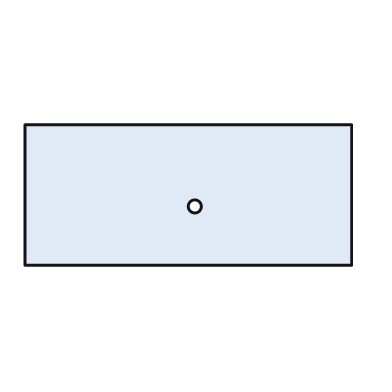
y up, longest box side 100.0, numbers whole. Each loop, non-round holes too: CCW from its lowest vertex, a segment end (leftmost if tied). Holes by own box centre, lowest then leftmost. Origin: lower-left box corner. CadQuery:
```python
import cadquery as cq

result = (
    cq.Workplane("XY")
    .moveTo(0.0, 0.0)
    .lineTo(100.0, 0.0)
    .lineTo(100.0, 43.0)
    .lineTo(0.0, 43.0)
    .close()
    .moveTo(52.0, 18.0)
    .circle(2.0)
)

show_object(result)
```